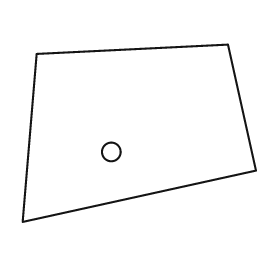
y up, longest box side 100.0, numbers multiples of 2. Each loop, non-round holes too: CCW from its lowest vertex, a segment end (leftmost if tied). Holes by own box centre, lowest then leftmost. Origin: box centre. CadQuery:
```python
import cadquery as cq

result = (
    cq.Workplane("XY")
    .moveTo(-50.0, -38.0)
    .lineTo(50.0, -16.0)
    .lineTo(38.0, 38.0)
    .lineTo(-44.0, 34.0)
    .close()
    .moveTo(-12.0, -8.0)
    .circle(4.0)
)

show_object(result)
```